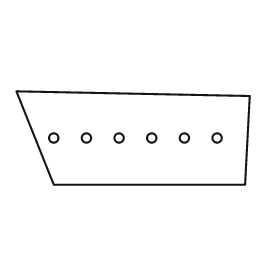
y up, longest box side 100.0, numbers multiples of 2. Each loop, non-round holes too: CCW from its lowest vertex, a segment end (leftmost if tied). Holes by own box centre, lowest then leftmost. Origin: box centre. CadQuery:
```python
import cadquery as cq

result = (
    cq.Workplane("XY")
    .moveTo(-34.0, -20.0)
    .lineTo(48.0, -20.0)
    .lineTo(50.0, 18.0)
    .lineTo(-50.0, 20.0)
    .close()
    .moveTo(-34.0, 0.0)
    .circle(2.0)
    .moveTo(-20.0, 0.0)
    .circle(2.0)
    .moveTo(-6.0, 0.0)
    .circle(2.0)
    .moveTo(8.0, 0.0)
    .circle(2.0)
    .moveTo(22.0, 0.0)
    .circle(2.0)
    .moveTo(36.0, 0.0)
    .circle(2.0)
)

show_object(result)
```